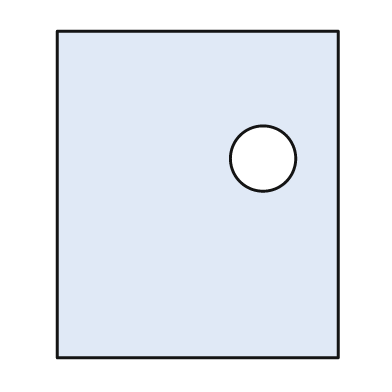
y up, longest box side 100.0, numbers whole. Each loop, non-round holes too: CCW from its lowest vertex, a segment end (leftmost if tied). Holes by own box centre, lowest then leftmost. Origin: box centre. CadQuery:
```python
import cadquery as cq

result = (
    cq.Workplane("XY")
    .moveTo(-43.0, -50.0)
    .lineTo(43.0, -50.0)
    .lineTo(43.0, 50.0)
    .lineTo(-43.0, 50.0)
    .close()
    .moveTo(20.0, 11.0)
    .circle(10.0)
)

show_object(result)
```